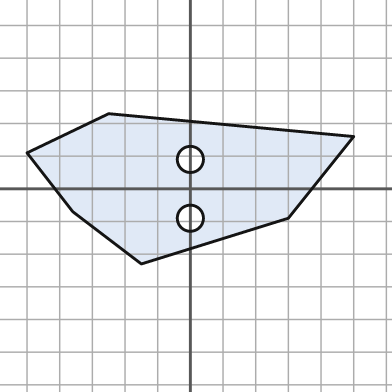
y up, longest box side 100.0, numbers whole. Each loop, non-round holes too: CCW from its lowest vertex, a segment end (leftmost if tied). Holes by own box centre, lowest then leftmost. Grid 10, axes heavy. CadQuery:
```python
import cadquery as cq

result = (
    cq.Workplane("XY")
    .moveTo(-15.0, -23.0)
    .lineTo(30.0, -9.0)
    .lineTo(50.0, 16.0)
    .lineTo(-25.0, 23.0)
    .lineTo(-50.0, 11.0)
    .lineTo(-36.0, -7.0)
    .close()
    .moveTo(0.0, -9.0)
    .circle(4.0)
    .moveTo(0.0, 9.0)
    .circle(4.0)
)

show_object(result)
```